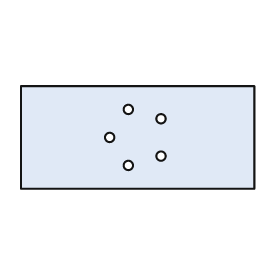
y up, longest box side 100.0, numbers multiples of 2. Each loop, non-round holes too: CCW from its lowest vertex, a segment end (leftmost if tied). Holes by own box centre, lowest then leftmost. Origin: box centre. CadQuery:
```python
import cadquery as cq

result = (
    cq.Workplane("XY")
    .moveTo(-50.0, -22.0)
    .lineTo(50.0, -22.0)
    .lineTo(50.0, 22.0)
    .lineTo(-50.0, 22.0)
    .close()
    .moveTo(-4.0, -12.0)
    .circle(2.0)
    .moveTo(10.0, -8.0)
    .circle(2.0)
    .moveTo(-12.0, 0.0)
    .circle(2.0)
    .moveTo(10.0, 8.0)
    .circle(2.0)
    .moveTo(-4.0, 12.0)
    .circle(2.0)
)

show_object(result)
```